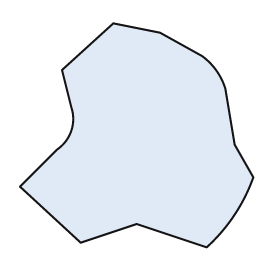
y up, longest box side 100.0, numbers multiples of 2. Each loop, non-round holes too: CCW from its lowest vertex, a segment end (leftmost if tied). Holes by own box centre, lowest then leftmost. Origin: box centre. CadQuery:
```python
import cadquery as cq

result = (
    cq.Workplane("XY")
    .moveTo(30.0, -48.0)
    .threePointArc((42.0, -34.0), (50.0, -18.0))
    .lineTo(42.0, -4.0)
    .lineTo(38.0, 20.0)
    .threePointArc((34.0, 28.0), (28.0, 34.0))
    .lineTo(10.0, 44.0)
    .lineTo(-10.0, 48.0)
    .lineTo(-32.0, 28.0)
    .lineTo(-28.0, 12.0)
    .threePointArc((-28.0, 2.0), (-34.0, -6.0))
    .lineTo(-50.0, -22.0)
    .lineTo(-24.0, -46.0)
    .lineTo(0.0, -38.0)
    .close()
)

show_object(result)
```